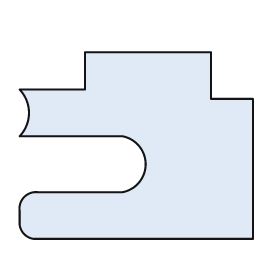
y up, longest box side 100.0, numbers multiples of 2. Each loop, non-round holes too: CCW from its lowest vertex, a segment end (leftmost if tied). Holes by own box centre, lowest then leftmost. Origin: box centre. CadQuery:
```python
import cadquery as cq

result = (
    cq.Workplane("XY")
    .moveTo(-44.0, -40.0)
    .lineTo(50.0, -40.0)
    .lineTo(50.0, 20.0)
    .lineTo(32.0, 20.0)
    .lineTo(32.0, 40.0)
    .lineTo(-22.0, 40.0)
    .lineTo(-22.0, 24.0)
    .lineTo(-50.0, 24.0)
    .threePointArc((-46.0, 14.0), (-50.0, 4.0))
    .lineTo(-6.0, 4.0)
    .threePointArc((4.0, -8.0), (-6.0, -20.0))
    .lineTo(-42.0, -20.0)
    .threePointArc((-48.0, -22.0), (-50.0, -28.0))
    .lineTo(-50.0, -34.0)
    .threePointArc((-48.0, -38.0), (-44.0, -40.0))
    .close()
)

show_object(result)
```